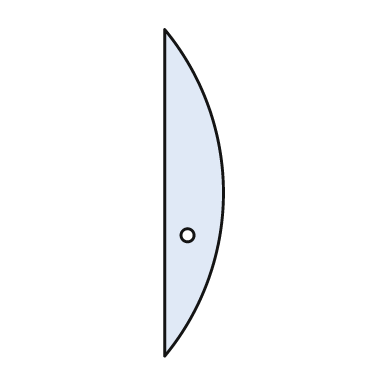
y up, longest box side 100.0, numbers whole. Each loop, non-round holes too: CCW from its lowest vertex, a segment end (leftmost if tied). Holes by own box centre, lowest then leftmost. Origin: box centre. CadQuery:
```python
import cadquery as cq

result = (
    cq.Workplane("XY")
    .moveTo(-9.0, -50.0)
    .threePointArc((9.0, 0.0), (-9.0, 50.0))
    .close()
    .moveTo(-2.0, -13.0)
    .circle(2.0)
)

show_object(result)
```